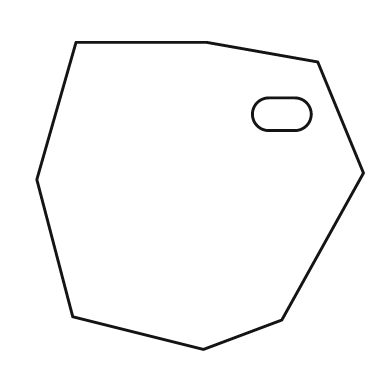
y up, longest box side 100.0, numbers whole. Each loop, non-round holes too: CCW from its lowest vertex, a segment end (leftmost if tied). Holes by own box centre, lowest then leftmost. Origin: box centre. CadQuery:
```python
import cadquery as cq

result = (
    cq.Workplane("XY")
    .moveTo(1.0, -47.0)
    .lineTo(25.0, -38.0)
    .lineTo(50.0, 7.0)
    .lineTo(36.0, 41.0)
    .lineTo(2.0, 47.0)
    .lineTo(-38.0, 47.0)
    .lineTo(-50.0, 5.0)
    .lineTo(-39.0, -37.0)
    .close()
    .moveTo(21.0, 20.0)
    .lineTo(29.0, 20.0)
    .threePointArc((34.0, 25.0), (29.0, 30.0))
    .lineTo(21.0, 30.0)
    .threePointArc((16.0, 25.0), (21.0, 20.0))
    .close()
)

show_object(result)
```